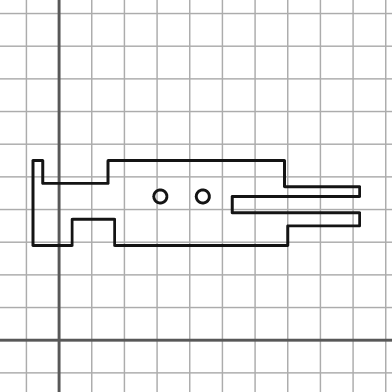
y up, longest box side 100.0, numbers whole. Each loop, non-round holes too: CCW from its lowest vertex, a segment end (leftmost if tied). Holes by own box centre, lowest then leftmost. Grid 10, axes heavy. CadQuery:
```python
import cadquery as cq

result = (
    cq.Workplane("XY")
    .moveTo(-8.0, 29.0)
    .lineTo(4.0, 29.0)
    .lineTo(4.0, 37.0)
    .lineTo(17.0, 37.0)
    .lineTo(17.0, 29.0)
    .lineTo(70.0, 29.0)
    .lineTo(70.0, 35.0)
    .lineTo(92.0, 35.0)
    .lineTo(92.0, 39.0)
    .lineTo(53.0, 39.0)
    .lineTo(53.0, 44.0)
    .lineTo(92.0, 44.0)
    .lineTo(92.0, 47.0)
    .lineTo(69.0, 47.0)
    .lineTo(69.0, 55.0)
    .lineTo(15.0, 55.0)
    .lineTo(15.0, 48.0)
    .lineTo(-5.0, 48.0)
    .lineTo(-5.0, 55.0)
    .lineTo(-8.0, 55.0)
    .close()
    .moveTo(31.0, 44.0)
    .circle(2.0)
    .moveTo(44.0, 44.0)
    .circle(2.0)
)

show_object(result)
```